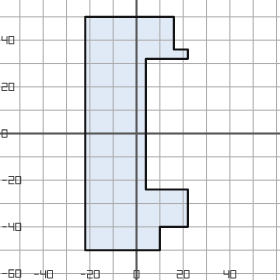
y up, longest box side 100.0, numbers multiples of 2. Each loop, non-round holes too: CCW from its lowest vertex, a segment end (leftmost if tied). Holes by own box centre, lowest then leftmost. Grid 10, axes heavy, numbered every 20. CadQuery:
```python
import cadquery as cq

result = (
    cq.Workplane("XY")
    .moveTo(-22.0, -50.0)
    .lineTo(10.0, -50.0)
    .lineTo(10.0, -40.0)
    .lineTo(22.0, -40.0)
    .lineTo(22.0, -24.0)
    .lineTo(4.0, -24.0)
    .lineTo(4.0, 32.0)
    .lineTo(22.0, 32.0)
    .lineTo(22.0, 36.0)
    .lineTo(16.0, 36.0)
    .lineTo(16.0, 50.0)
    .lineTo(-22.0, 50.0)
    .close()
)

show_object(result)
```